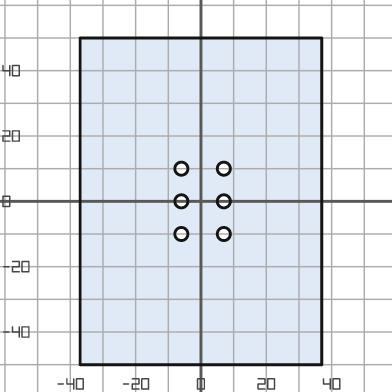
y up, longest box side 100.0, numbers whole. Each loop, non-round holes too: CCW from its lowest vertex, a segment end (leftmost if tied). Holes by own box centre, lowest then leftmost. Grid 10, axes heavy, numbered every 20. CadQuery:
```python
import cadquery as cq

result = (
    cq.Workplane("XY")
    .moveTo(-37.0, -50.0)
    .lineTo(37.0, -50.0)
    .lineTo(37.0, 50.0)
    .lineTo(-37.0, 50.0)
    .close()
    .moveTo(-6.0, -10.0)
    .circle(2.0)
    .moveTo(7.0, -10.0)
    .circle(2.0)
    .moveTo(-6.0, 0.0)
    .circle(2.0)
    .moveTo(7.0, 0.0)
    .circle(2.0)
    .moveTo(-6.0, 10.0)
    .circle(2.0)
    .moveTo(7.0, 10.0)
    .circle(2.0)
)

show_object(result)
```